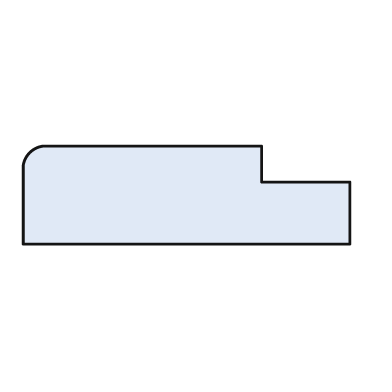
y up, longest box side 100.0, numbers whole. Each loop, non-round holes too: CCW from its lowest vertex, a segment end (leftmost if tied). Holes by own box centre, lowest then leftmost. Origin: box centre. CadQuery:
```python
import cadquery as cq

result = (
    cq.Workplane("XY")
    .moveTo(-50.0, -15.0)
    .lineTo(50.0, -15.0)
    .lineTo(50.0, 4.0)
    .lineTo(23.0, 4.0)
    .lineTo(23.0, 15.0)
    .lineTo(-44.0, 15.0)
    .threePointArc((-48.0, 13.0), (-50.0, 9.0))
    .close()
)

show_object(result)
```